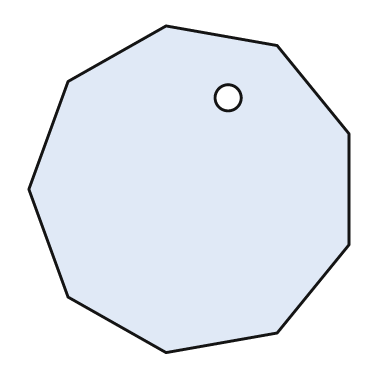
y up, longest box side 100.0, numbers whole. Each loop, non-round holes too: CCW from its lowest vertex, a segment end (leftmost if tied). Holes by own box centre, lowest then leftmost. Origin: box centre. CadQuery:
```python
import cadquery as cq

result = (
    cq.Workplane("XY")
    .moveTo(-7.0, -50.0)
    .lineTo(27.0, -44.0)
    .lineTo(49.0, -17.0)
    .lineTo(49.0, 17.0)
    .lineTo(27.0, 44.0)
    .lineTo(-7.0, 50.0)
    .lineTo(-37.0, 33.0)
    .lineTo(-49.0, 0.0)
    .lineTo(-37.0, -33.0)
    .close()
    .moveTo(12.0, 28.0)
    .circle(4.0)
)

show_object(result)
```